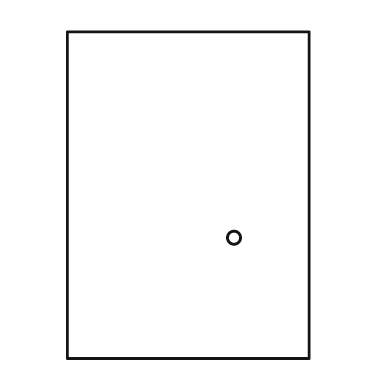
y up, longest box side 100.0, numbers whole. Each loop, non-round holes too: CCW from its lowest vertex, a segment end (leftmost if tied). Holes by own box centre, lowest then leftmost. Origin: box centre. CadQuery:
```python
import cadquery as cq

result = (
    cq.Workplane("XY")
    .moveTo(-37.0, -50.0)
    .lineTo(37.0, -50.0)
    .lineTo(37.0, 50.0)
    .lineTo(-37.0, 50.0)
    .close()
    .moveTo(14.0, -13.0)
    .circle(2.0)
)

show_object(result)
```